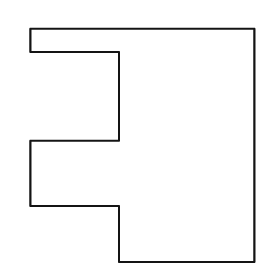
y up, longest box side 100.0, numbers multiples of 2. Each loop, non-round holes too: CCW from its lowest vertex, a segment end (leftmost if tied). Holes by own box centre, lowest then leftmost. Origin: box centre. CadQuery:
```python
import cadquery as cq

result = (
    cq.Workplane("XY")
    .moveTo(-10.0, -50.0)
    .lineTo(48.0, -50.0)
    .lineTo(48.0, 50.0)
    .lineTo(-48.0, 50.0)
    .lineTo(-48.0, 40.0)
    .lineTo(-10.0, 40.0)
    .lineTo(-10.0, 2.0)
    .lineTo(-48.0, 2.0)
    .lineTo(-48.0, -26.0)
    .lineTo(-10.0, -26.0)
    .close()
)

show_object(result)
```